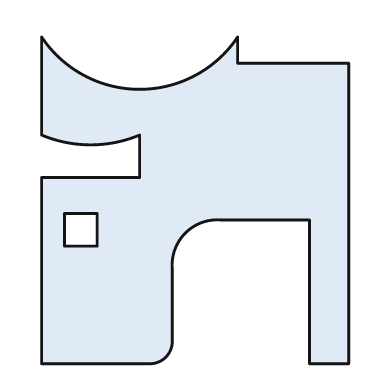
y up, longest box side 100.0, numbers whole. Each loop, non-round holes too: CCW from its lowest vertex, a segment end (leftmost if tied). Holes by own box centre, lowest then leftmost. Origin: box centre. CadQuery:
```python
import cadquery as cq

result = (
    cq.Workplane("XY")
    .moveTo(-47.0, -50.0)
    .lineTo(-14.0, -50.0)
    .threePointArc((-9.0, -48.0), (-7.0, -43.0))
    .lineTo(-7.0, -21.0)
    .threePointArc((-3.0, -10.0), (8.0, -6.0))
    .lineTo(35.0, -6.0)
    .lineTo(35.0, -50.0)
    .lineTo(47.0, -50.0)
    .lineTo(47.0, 42.0)
    .lineTo(13.0, 42.0)
    .lineTo(13.0, 50.0)
    .threePointArc((-17.0, 34.0), (-47.0, 50.0))
    .lineTo(-47.0, 20.0)
    .threePointArc((-32.0, 17.0), (-17.0, 20.0))
    .lineTo(-17.0, 7.0)
    .lineTo(-47.0, 7.0)
    .close()
    .moveTo(-40.0, -14.0)
    .lineTo(-30.0, -14.0)
    .lineTo(-30.0, -4.0)
    .lineTo(-40.0, -4.0)
    .close()
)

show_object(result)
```